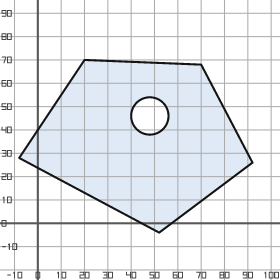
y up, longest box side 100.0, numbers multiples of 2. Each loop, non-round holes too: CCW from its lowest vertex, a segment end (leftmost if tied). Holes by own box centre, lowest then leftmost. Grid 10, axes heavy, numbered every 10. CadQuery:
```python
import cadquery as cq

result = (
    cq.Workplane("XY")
    .moveTo(52.0, -4.0)
    .lineTo(92.0, 26.0)
    .lineTo(70.0, 68.0)
    .lineTo(20.0, 70.0)
    .lineTo(-8.0, 28.0)
    .close()
    .moveTo(48.0, 46.0)
    .circle(8.0)
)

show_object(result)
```